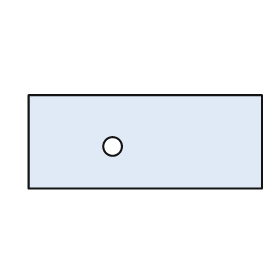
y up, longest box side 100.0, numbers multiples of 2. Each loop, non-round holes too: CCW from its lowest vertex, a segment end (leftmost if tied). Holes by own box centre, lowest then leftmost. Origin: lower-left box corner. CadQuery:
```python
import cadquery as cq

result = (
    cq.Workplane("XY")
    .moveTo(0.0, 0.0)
    .lineTo(100.0, 0.0)
    .lineTo(100.0, 40.0)
    .lineTo(0.0, 40.0)
    .close()
    .moveTo(36.0, 18.0)
    .circle(4.0)
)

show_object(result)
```